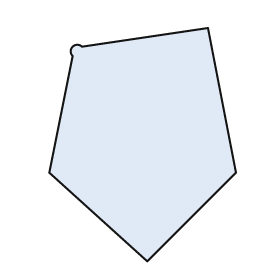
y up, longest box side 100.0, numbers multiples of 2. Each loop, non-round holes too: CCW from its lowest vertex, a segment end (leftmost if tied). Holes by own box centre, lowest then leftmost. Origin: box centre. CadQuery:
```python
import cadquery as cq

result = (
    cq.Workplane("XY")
    .moveTo(2.0, -50.0)
    .lineTo(40.0, -12.0)
    .lineTo(28.0, 50.0)
    .lineTo(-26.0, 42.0)
    .threePointArc((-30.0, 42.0), (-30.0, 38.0))
    .lineTo(-40.0, -12.0)
    .close()
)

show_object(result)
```